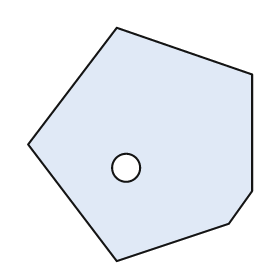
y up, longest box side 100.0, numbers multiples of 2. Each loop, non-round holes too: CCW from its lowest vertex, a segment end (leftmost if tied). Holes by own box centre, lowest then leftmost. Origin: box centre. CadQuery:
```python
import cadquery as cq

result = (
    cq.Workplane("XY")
    .moveTo(-10.0, -50.0)
    .lineTo(38.0, -34.0)
    .lineTo(48.0, -20.0)
    .lineTo(48.0, 30.0)
    .lineTo(-10.0, 50.0)
    .lineTo(-48.0, 0.0)
    .close()
    .moveTo(-6.0, -10.0)
    .circle(6.0)
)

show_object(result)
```